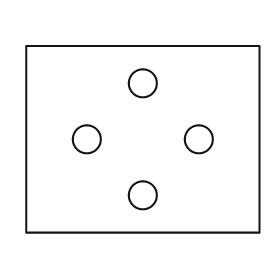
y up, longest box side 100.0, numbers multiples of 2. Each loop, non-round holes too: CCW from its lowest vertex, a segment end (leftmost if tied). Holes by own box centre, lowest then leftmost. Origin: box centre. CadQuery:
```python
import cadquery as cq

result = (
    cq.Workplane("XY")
    .moveTo(-50.0, -40.0)
    .lineTo(50.0, -40.0)
    .lineTo(50.0, 40.0)
    .lineTo(-50.0, 40.0)
    .close()
    .moveTo(0.0, -24.0)
    .circle(6.0)
    .moveTo(-24.0, 0.0)
    .circle(6.0)
    .moveTo(24.0, 0.0)
    .circle(6.0)
    .moveTo(0.0, 24.0)
    .circle(6.0)
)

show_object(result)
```